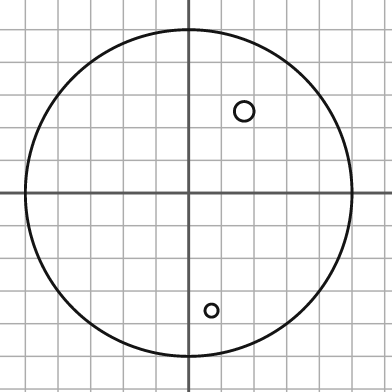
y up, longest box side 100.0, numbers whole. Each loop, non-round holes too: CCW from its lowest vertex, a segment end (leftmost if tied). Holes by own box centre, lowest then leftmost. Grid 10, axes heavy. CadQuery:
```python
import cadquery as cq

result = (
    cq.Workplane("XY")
    .moveTo(0.0, 0.0)
    .circle(50.0)
    .moveTo(7.0, -36.0)
    .circle(2.0)
    .moveTo(17.0, 25.0)
    .circle(3.0)
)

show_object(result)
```